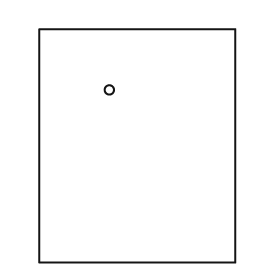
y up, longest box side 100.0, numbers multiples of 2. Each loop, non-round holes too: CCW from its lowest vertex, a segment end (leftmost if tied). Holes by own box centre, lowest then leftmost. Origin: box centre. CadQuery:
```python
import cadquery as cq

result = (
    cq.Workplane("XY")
    .moveTo(-42.0, -50.0)
    .lineTo(42.0, -50.0)
    .lineTo(42.0, 50.0)
    .lineTo(-42.0, 50.0)
    .close()
    .moveTo(-12.0, 24.0)
    .circle(2.0)
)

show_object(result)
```